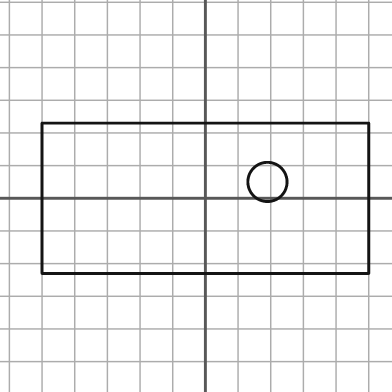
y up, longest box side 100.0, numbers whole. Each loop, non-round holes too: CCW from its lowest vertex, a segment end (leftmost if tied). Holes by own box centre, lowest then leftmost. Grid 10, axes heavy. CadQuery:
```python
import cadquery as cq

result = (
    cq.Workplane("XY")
    .moveTo(-50.0, -23.0)
    .lineTo(50.0, -23.0)
    .lineTo(50.0, 23.0)
    .lineTo(-50.0, 23.0)
    .close()
    .moveTo(19.0, 5.0)
    .circle(6.0)
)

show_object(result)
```